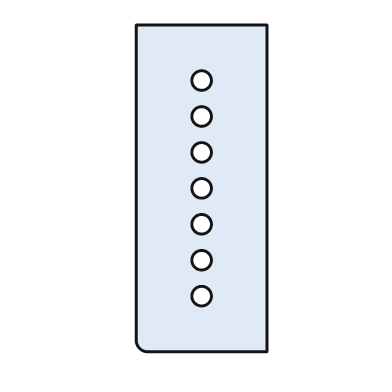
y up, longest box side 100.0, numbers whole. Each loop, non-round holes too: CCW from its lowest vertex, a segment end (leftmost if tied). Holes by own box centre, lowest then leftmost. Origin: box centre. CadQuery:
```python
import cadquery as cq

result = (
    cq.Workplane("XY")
    .moveTo(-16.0, -50.0)
    .lineTo(20.0, -50.0)
    .lineTo(20.0, 50.0)
    .lineTo(-20.0, 50.0)
    .lineTo(-20.0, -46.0)
    .threePointArc((-19.0, -49.0), (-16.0, -50.0))
    .close()
    .moveTo(0.0, -33.0)
    .circle(3.0)
    .moveTo(0.0, -22.0)
    .circle(3.0)
    .moveTo(0.0, -11.0)
    .circle(3.0)
    .moveTo(0.0, 0.0)
    .circle(3.0)
    .moveTo(0.0, 11.0)
    .circle(3.0)
    .moveTo(0.0, 22.0)
    .circle(3.0)
    .moveTo(0.0, 33.0)
    .circle(3.0)
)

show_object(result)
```